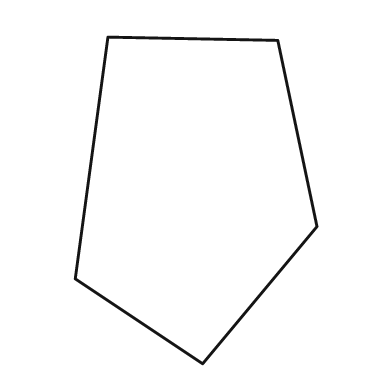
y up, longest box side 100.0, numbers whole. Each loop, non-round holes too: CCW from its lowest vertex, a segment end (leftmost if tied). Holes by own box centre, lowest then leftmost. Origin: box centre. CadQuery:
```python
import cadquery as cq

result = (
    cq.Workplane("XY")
    .moveTo(2.0, -50.0)
    .lineTo(37.0, -8.0)
    .lineTo(25.0, 49.0)
    .lineTo(-27.0, 50.0)
    .lineTo(-37.0, -24.0)
    .close()
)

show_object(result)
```